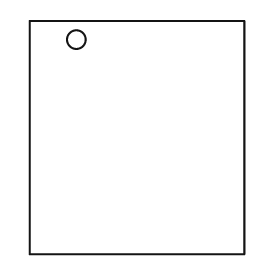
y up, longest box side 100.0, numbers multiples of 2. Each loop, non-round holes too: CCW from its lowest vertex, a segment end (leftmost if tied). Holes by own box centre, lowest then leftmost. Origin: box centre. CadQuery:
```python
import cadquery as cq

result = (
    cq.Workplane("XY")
    .moveTo(-46.0, -50.0)
    .lineTo(46.0, -50.0)
    .lineTo(46.0, 50.0)
    .lineTo(-46.0, 50.0)
    .close()
    .moveTo(-26.0, 42.0)
    .circle(4.0)
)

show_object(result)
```